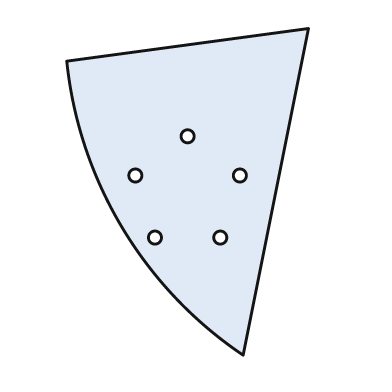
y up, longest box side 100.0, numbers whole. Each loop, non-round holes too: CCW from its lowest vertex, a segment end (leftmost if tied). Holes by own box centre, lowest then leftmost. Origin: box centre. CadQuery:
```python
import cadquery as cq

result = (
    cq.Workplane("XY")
    .moveTo(17.0, -50.0)
    .lineTo(37.0, 50.0)
    .lineTo(-37.0, 40.0)
    .threePointArc((-20.0, -11.0), (17.0, -50.0))
    .close()
    .moveTo(-10.0, -14.0)
    .circle(2.0)
    .moveTo(10.0, -14.0)
    .circle(2.0)
    .moveTo(-16.0, 5.0)
    .circle(2.0)
    .moveTo(16.0, 5.0)
    .circle(2.0)
    .moveTo(0.0, 17.0)
    .circle(2.0)
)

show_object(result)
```